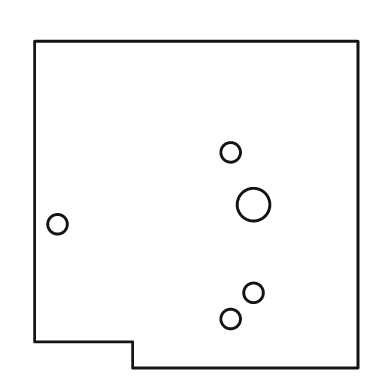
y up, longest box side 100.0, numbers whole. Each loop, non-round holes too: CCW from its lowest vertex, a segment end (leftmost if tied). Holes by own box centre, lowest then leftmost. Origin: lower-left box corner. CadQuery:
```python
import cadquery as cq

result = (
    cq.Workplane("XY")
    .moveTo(30.0, 0.0)
    .lineTo(99.0, 0.0)
    .lineTo(99.0, 100.0)
    .lineTo(0.0, 100.0)
    .lineTo(0.0, 8.0)
    .lineTo(30.0, 8.0)
    .close()
    .moveTo(60.0, 15.0)
    .circle(3.0)
    .moveTo(67.0, 23.0)
    .circle(3.0)
    .moveTo(7.0, 44.0)
    .circle(3.0)
    .moveTo(67.0, 50.0)
    .circle(5.0)
    .moveTo(60.0, 66.0)
    .circle(3.0)
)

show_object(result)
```